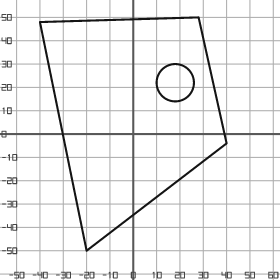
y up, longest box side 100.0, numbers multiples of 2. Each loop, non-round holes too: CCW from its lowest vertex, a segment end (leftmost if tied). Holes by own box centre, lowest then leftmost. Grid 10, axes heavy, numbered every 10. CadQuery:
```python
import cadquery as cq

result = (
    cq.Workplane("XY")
    .moveTo(-20.0, -50.0)
    .lineTo(40.0, -4.0)
    .lineTo(28.0, 50.0)
    .lineTo(-40.0, 48.0)
    .close()
    .moveTo(18.0, 22.0)
    .circle(8.0)
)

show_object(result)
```